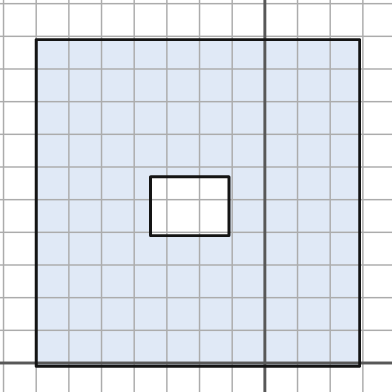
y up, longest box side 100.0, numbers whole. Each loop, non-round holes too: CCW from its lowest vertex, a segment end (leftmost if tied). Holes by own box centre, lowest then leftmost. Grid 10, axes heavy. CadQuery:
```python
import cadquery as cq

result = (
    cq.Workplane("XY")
    .moveTo(-70.0, -1.0)
    .lineTo(29.0, -1.0)
    .lineTo(29.0, 99.0)
    .lineTo(-70.0, 99.0)
    .close()
    .moveTo(-35.0, 39.0)
    .lineTo(-11.0, 39.0)
    .lineTo(-11.0, 57.0)
    .lineTo(-35.0, 57.0)
    .close()
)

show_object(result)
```